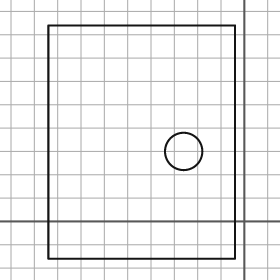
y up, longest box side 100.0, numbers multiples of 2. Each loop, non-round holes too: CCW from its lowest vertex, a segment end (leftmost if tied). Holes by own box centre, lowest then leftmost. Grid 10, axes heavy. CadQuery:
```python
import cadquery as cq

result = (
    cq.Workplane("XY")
    .moveTo(-84.0, -16.0)
    .lineTo(-4.0, -16.0)
    .lineTo(-4.0, 84.0)
    .lineTo(-84.0, 84.0)
    .close()
    .moveTo(-26.0, 30.0)
    .circle(8.0)
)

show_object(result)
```